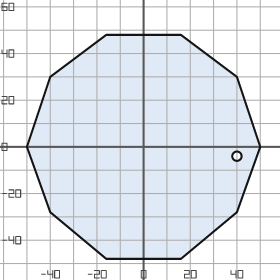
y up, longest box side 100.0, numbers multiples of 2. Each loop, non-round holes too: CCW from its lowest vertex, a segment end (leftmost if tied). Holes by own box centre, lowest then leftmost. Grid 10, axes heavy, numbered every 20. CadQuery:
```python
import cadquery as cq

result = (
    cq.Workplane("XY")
    .moveTo(-16.0, -48.0)
    .lineTo(16.0, -48.0)
    .lineTo(40.0, -28.0)
    .lineTo(50.0, 0.0)
    .lineTo(40.0, 30.0)
    .lineTo(16.0, 48.0)
    .lineTo(-16.0, 48.0)
    .lineTo(-40.0, 30.0)
    .lineTo(-50.0, 0.0)
    .lineTo(-40.0, -28.0)
    .close()
    .moveTo(40.0, -4.0)
    .circle(2.0)
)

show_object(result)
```